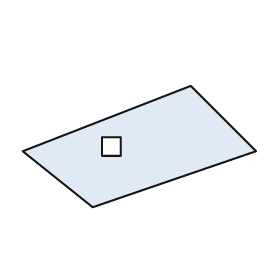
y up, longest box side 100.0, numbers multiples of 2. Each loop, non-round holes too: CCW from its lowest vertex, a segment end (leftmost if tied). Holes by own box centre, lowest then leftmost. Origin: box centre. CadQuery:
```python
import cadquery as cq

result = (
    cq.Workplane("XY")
    .moveTo(-20.0, -26.0)
    .lineTo(50.0, -2.0)
    .lineTo(22.0, 26.0)
    .lineTo(-50.0, -2.0)
    .close()
    .moveTo(-16.0, -4.0)
    .lineTo(-8.0, -4.0)
    .lineTo(-8.0, 4.0)
    .lineTo(-16.0, 4.0)
    .close()
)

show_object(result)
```